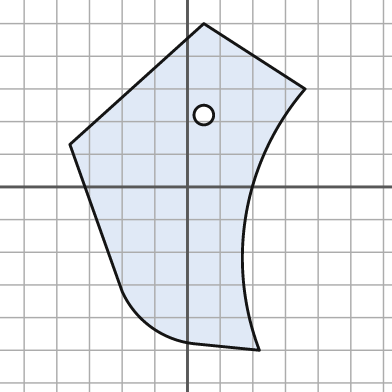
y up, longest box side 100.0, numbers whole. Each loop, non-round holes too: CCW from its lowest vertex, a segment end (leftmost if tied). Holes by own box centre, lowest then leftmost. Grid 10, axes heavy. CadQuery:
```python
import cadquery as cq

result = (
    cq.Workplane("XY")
    .moveTo(22.0, -50.0)
    .threePointArc((18.0, -8.0), (36.0, 30.0))
    .lineTo(5.0, 50.0)
    .lineTo(-36.0, 13.0)
    .lineTo(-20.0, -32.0)
    .threePointArc((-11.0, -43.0), (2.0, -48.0))
    .close()
    .moveTo(5.0, 22.0)
    .circle(3.0)
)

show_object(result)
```